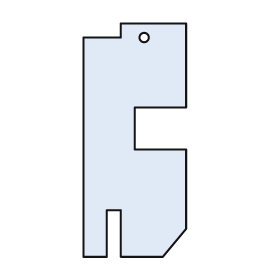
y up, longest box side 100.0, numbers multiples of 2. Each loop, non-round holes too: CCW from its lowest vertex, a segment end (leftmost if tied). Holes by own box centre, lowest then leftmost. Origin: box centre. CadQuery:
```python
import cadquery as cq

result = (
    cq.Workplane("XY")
    .moveTo(-22.0, -50.0)
    .lineTo(-12.0, -50.0)
    .lineTo(-12.0, -30.0)
    .lineTo(-6.0, -30.0)
    .lineTo(-6.0, -50.0)
    .lineTo(12.0, -50.0)
    .lineTo(22.0, -38.0)
    .lineTo(22.0, -4.0)
    .lineTo(0.0, -4.0)
    .lineTo(0.0, 14.0)
    .lineTo(22.0, 14.0)
    .lineTo(22.0, 50.0)
    .lineTo(-6.0, 50.0)
    .lineTo(-6.0, 44.0)
    .lineTo(-22.0, 44.0)
    .close()
    .moveTo(4.0, 44.0)
    .circle(2.0)
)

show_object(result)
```